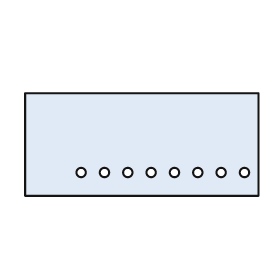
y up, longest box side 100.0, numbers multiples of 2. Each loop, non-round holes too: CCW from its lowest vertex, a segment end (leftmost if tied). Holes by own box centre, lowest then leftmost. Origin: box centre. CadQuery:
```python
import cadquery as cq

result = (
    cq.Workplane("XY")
    .moveTo(-50.0, -22.0)
    .lineTo(50.0, -22.0)
    .lineTo(50.0, 22.0)
    .lineTo(-50.0, 22.0)
    .close()
    .moveTo(-26.0, -12.0)
    .circle(2.0)
    .moveTo(-16.0, -12.0)
    .circle(2.0)
    .moveTo(-6.0, -12.0)
    .circle(2.0)
    .moveTo(4.0, -12.0)
    .circle(2.0)
    .moveTo(14.0, -12.0)
    .circle(2.0)
    .moveTo(24.0, -12.0)
    .circle(2.0)
    .moveTo(34.0, -12.0)
    .circle(2.0)
    .moveTo(44.0, -12.0)
    .circle(2.0)
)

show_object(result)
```